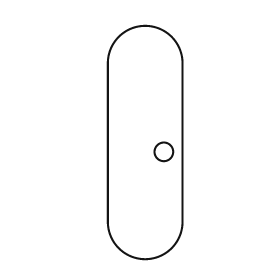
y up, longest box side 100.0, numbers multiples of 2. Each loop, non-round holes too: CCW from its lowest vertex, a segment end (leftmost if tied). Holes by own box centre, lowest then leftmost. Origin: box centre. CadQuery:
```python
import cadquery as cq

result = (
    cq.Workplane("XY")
    .moveTo(-16.0, -34.0)
    .threePointArc((0.0, -50.0), (16.0, -34.0))
    .lineTo(16.0, 34.0)
    .threePointArc((0.0, 50.0), (-16.0, 34.0))
    .close()
    .moveTo(8.0, -4.0)
    .circle(4.0)
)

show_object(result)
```